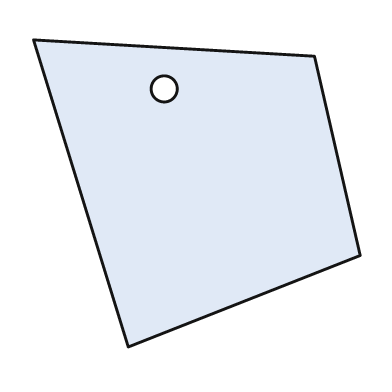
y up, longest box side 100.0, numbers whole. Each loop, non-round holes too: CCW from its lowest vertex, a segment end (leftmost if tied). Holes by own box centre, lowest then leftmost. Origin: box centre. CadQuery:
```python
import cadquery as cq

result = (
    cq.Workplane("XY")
    .moveTo(-21.0, -47.0)
    .lineTo(50.0, -19.0)
    .lineTo(36.0, 42.0)
    .lineTo(-50.0, 47.0)
    .close()
    .moveTo(-10.0, 32.0)
    .circle(4.0)
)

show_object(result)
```